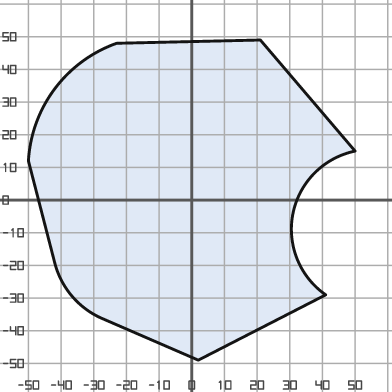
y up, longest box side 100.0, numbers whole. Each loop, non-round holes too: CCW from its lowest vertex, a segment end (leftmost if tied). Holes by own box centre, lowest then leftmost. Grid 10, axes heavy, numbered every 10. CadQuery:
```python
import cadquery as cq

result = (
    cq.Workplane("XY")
    .moveTo(2.0, -49.0)
    .lineTo(41.0, -29.0)
    .threePointArc((31.0, -4.0), (50.0, 15.0))
    .lineTo(21.0, 49.0)
    .lineTo(-23.0, 48.0)
    .threePointArc((-42.0, 34.0), (-50.0, 12.0))
    .lineTo(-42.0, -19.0)
    .threePointArc((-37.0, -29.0), (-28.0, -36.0))
    .close()
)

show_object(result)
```